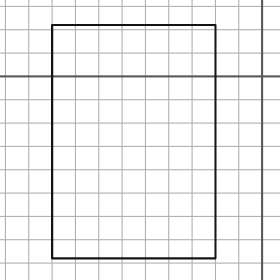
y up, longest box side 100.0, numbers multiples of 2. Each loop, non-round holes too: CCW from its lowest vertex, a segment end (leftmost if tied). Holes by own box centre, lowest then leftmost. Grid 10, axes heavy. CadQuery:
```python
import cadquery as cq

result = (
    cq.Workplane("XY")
    .moveTo(-90.0, -78.0)
    .lineTo(-20.0, -78.0)
    .lineTo(-20.0, 22.0)
    .lineTo(-90.0, 22.0)
    .close()
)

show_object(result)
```